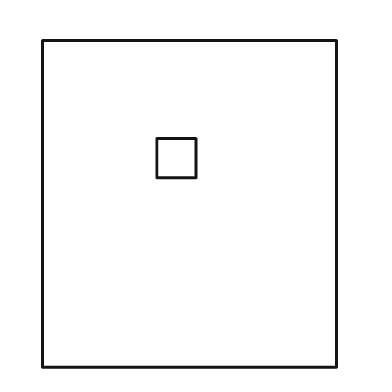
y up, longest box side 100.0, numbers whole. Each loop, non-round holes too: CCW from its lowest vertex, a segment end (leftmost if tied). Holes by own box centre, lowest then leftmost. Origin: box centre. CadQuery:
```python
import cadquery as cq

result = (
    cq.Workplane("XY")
    .moveTo(-45.0, -50.0)
    .lineTo(45.0, -50.0)
    .lineTo(45.0, 50.0)
    .lineTo(-45.0, 50.0)
    .close()
    .moveTo(-10.0, 8.0)
    .lineTo(2.0, 8.0)
    .lineTo(2.0, 20.0)
    .lineTo(-10.0, 20.0)
    .close()
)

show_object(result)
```